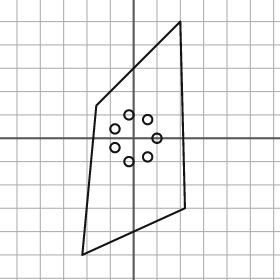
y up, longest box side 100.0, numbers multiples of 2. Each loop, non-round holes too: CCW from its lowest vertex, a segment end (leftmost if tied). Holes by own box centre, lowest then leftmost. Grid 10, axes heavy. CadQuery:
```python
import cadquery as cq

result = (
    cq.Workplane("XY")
    .moveTo(-22.0, -50.0)
    .lineTo(22.0, -30.0)
    .lineTo(20.0, 50.0)
    .lineTo(-16.0, 14.0)
    .close()
    .moveTo(-2.0, -10.0)
    .circle(2.0)
    .moveTo(6.0, -8.0)
    .circle(2.0)
    .moveTo(-8.0, -4.0)
    .circle(2.0)
    .moveTo(10.0, 0.0)
    .circle(2.0)
    .moveTo(-8.0, 4.0)
    .circle(2.0)
    .moveTo(6.0, 8.0)
    .circle(2.0)
    .moveTo(-2.0, 10.0)
    .circle(2.0)
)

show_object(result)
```